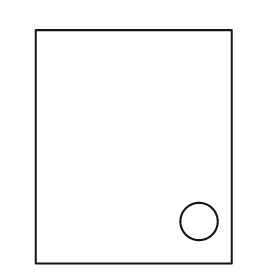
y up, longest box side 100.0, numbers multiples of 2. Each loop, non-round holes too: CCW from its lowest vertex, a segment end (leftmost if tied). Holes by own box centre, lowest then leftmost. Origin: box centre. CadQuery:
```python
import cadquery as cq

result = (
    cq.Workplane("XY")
    .moveTo(-42.0, -50.0)
    .lineTo(42.0, -50.0)
    .lineTo(42.0, 50.0)
    .lineTo(-42.0, 50.0)
    .close()
    .moveTo(28.0, -32.0)
    .circle(8.0)
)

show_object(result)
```